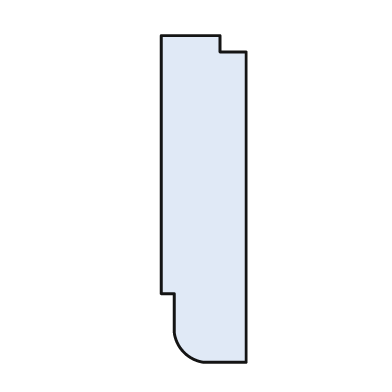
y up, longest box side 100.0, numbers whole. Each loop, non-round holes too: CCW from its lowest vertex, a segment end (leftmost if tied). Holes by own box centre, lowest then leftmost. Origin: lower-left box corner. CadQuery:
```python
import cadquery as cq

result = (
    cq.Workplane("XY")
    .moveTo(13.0, 0.0)
    .lineTo(26.0, 0.0)
    .lineTo(26.0, 95.0)
    .lineTo(18.0, 95.0)
    .lineTo(18.0, 100.0)
    .lineTo(0.0, 100.0)
    .lineTo(0.0, 21.0)
    .lineTo(4.0, 21.0)
    .lineTo(4.0, 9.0)
    .threePointArc((7.0, 3.0), (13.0, 0.0))
    .close()
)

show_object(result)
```